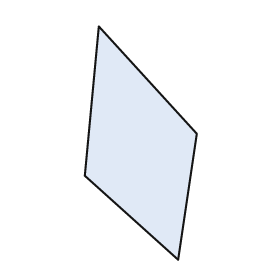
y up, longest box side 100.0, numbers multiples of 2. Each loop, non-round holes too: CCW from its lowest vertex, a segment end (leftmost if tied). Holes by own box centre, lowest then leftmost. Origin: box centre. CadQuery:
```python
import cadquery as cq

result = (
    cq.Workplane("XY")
    .moveTo(16.0, -50.0)
    .lineTo(24.0, 4.0)
    .lineTo(-18.0, 50.0)
    .lineTo(-24.0, -14.0)
    .close()
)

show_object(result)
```